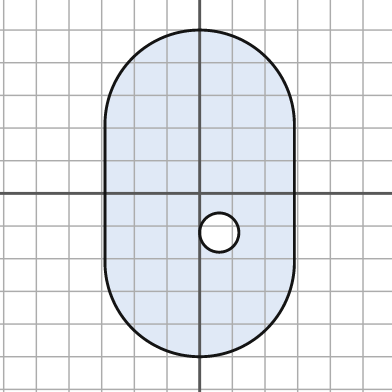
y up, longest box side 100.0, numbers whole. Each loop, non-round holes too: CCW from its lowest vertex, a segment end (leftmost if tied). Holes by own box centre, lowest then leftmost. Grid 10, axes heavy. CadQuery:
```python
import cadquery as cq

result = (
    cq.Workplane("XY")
    .moveTo(-29.0, -21.0)
    .threePointArc((0.0, -50.0), (29.0, -21.0))
    .lineTo(29.0, 21.0)
    .threePointArc((0.0, 50.0), (-29.0, 21.0))
    .close()
    .moveTo(6.0, -12.0)
    .circle(6.0)
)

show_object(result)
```